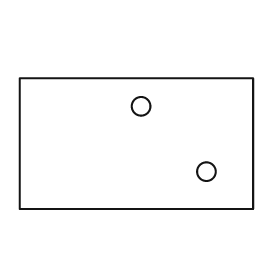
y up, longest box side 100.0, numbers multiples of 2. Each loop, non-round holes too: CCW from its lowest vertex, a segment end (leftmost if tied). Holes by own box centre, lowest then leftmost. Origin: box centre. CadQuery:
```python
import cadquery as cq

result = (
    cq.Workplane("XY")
    .moveTo(-50.0, -28.0)
    .lineTo(50.0, -28.0)
    .lineTo(50.0, 28.0)
    .lineTo(-50.0, 28.0)
    .close()
    .moveTo(30.0, -12.0)
    .circle(4.0)
    .moveTo(2.0, 16.0)
    .circle(4.0)
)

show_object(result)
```